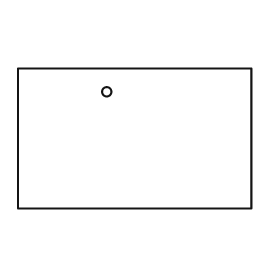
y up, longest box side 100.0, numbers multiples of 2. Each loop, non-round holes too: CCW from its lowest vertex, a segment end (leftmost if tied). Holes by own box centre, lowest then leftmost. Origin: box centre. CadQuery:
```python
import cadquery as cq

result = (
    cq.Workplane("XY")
    .moveTo(-50.0, -30.0)
    .lineTo(50.0, -30.0)
    .lineTo(50.0, 30.0)
    .lineTo(-50.0, 30.0)
    .close()
    .moveTo(-12.0, 20.0)
    .circle(2.0)
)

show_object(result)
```